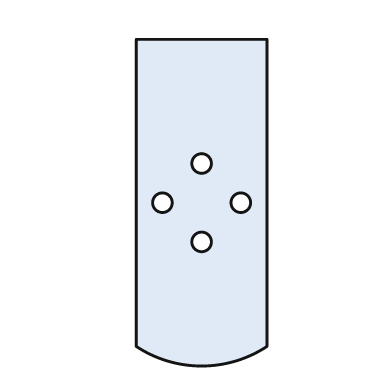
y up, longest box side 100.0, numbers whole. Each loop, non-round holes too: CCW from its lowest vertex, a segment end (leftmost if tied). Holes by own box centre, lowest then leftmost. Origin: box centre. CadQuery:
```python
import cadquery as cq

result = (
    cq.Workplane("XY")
    .moveTo(-20.0, -44.0)
    .threePointArc((0.0, -50.0), (20.0, -44.0))
    .lineTo(20.0, 50.0)
    .lineTo(-20.0, 50.0)
    .close()
    .moveTo(0.0, -12.0)
    .circle(3.0)
    .moveTo(-12.0, 0.0)
    .circle(3.0)
    .moveTo(12.0, 0.0)
    .circle(3.0)
    .moveTo(0.0, 12.0)
    .circle(3.0)
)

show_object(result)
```